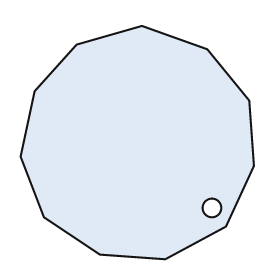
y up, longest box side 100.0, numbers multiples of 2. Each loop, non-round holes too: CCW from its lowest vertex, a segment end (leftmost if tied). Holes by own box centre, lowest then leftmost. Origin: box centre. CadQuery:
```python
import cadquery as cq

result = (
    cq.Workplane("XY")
    .moveTo(12.0, -50.0)
    .lineTo(38.0, -36.0)
    .lineTo(50.0, -10.0)
    .lineTo(48.0, 18.0)
    .lineTo(30.0, 40.0)
    .lineTo(2.0, 50.0)
    .lineTo(-26.0, 42.0)
    .lineTo(-44.0, 22.0)
    .lineTo(-50.0, -6.0)
    .lineTo(-40.0, -32.0)
    .lineTo(-16.0, -48.0)
    .close()
    .moveTo(32.0, -28.0)
    .circle(4.0)
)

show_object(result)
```